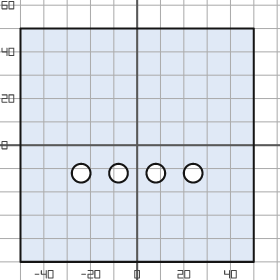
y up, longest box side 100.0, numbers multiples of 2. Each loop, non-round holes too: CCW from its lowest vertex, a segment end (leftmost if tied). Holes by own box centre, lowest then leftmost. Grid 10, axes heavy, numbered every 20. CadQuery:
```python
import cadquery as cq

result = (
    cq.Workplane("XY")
    .moveTo(-50.0, -50.0)
    .lineTo(50.0, -50.0)
    .lineTo(50.0, 50.0)
    .lineTo(-50.0, 50.0)
    .close()
    .moveTo(-24.0, -12.0)
    .circle(4.0)
    .moveTo(-8.0, -12.0)
    .circle(4.0)
    .moveTo(8.0, -12.0)
    .circle(4.0)
    .moveTo(24.0, -12.0)
    .circle(4.0)
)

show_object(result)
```